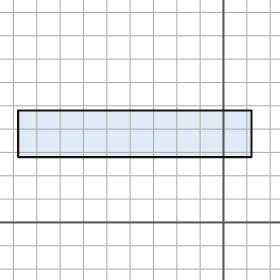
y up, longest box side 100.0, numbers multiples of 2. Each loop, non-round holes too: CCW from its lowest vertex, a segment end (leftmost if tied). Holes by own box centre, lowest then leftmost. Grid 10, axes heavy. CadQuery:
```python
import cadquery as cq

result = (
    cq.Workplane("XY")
    .moveTo(-88.0, 28.0)
    .lineTo(12.0, 28.0)
    .lineTo(12.0, 48.0)
    .lineTo(-88.0, 48.0)
    .close()
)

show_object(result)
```